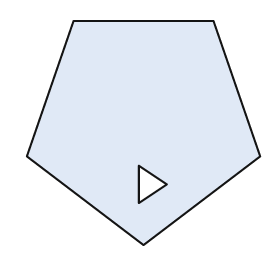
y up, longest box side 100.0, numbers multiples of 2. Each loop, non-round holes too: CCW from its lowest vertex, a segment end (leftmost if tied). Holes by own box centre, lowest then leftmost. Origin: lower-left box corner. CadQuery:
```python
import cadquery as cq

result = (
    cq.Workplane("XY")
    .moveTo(50.0, 0.0)
    .lineTo(100.0, 38.0)
    .lineTo(80.0, 96.0)
    .lineTo(20.0, 96.0)
    .lineTo(0.0, 38.0)
    .close()
    .moveTo(48.0, 18.0)
    .lineTo(60.0, 26.0)
    .lineTo(48.0, 34.0)
    .close()
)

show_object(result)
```